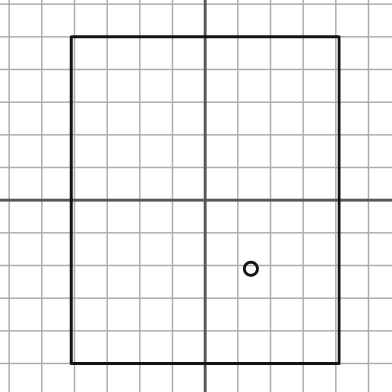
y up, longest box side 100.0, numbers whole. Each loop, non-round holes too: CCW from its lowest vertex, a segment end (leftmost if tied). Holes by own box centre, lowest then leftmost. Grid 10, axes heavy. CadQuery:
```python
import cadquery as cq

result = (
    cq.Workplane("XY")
    .moveTo(-41.0, -50.0)
    .lineTo(41.0, -50.0)
    .lineTo(41.0, 50.0)
    .lineTo(-41.0, 50.0)
    .close()
    .moveTo(14.0, -21.0)
    .circle(2.0)
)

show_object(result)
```